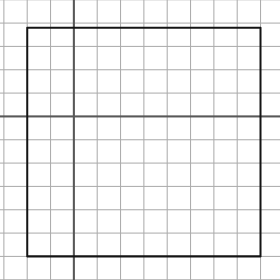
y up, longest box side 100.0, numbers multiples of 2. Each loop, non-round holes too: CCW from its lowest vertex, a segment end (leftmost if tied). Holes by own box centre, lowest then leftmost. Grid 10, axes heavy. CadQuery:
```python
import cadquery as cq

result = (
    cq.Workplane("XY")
    .moveTo(-20.0, -60.0)
    .lineTo(80.0, -60.0)
    .lineTo(80.0, 38.0)
    .lineTo(-20.0, 38.0)
    .close()
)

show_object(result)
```